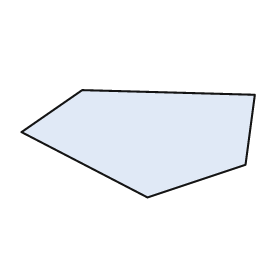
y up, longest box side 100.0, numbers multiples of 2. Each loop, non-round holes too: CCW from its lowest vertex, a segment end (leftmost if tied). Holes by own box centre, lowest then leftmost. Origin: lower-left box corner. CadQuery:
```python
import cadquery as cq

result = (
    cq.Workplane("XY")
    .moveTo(54.0, 0.0)
    .lineTo(96.0, 14.0)
    .lineTo(100.0, 44.0)
    .lineTo(26.0, 46.0)
    .lineTo(0.0, 28.0)
    .close()
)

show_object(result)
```